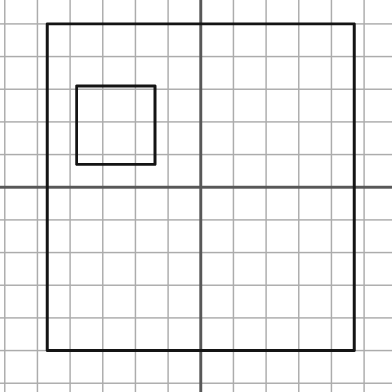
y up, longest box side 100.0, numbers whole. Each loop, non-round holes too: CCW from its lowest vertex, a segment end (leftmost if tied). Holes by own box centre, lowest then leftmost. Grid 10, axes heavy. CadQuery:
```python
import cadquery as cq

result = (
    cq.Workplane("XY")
    .moveTo(-47.0, -50.0)
    .lineTo(47.0, -50.0)
    .lineTo(47.0, 50.0)
    .lineTo(-47.0, 50.0)
    .close()
    .moveTo(-38.0, 7.0)
    .lineTo(-14.0, 7.0)
    .lineTo(-14.0, 31.0)
    .lineTo(-38.0, 31.0)
    .close()
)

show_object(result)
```